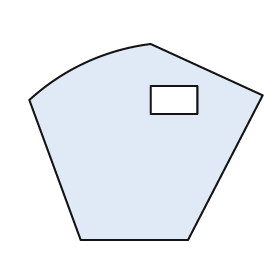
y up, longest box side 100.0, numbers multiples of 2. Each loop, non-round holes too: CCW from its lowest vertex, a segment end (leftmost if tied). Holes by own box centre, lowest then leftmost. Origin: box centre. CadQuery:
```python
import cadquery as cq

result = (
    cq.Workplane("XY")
    .moveTo(-28.0, -42.0)
    .lineTo(18.0, -42.0)
    .lineTo(50.0, 20.0)
    .lineTo(2.0, 42.0)
    .threePointArc((-26.0, 34.0), (-50.0, 18.0))
    .close()
    .moveTo(2.0, 12.0)
    .lineTo(22.0, 12.0)
    .lineTo(22.0, 24.0)
    .lineTo(2.0, 24.0)
    .close()
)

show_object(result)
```